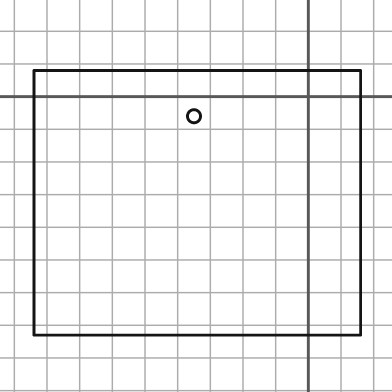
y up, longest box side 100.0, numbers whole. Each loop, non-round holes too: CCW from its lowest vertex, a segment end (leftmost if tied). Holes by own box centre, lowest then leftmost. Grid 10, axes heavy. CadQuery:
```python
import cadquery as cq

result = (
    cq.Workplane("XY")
    .moveTo(-84.0, -73.0)
    .lineTo(16.0, -73.0)
    .lineTo(16.0, 8.0)
    .lineTo(-84.0, 8.0)
    .close()
    .moveTo(-35.0, -6.0)
    .circle(2.0)
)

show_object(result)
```